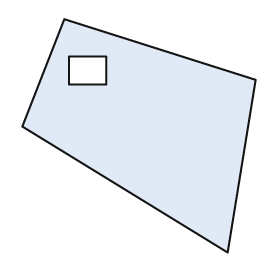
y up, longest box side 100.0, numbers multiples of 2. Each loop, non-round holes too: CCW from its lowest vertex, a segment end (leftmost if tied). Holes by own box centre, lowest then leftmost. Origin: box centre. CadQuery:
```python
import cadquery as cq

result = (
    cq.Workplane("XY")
    .moveTo(38.0, -50.0)
    .lineTo(50.0, 24.0)
    .lineTo(-32.0, 50.0)
    .lineTo(-50.0, 4.0)
    .close()
    .moveTo(-30.0, 22.0)
    .lineTo(-14.0, 22.0)
    .lineTo(-14.0, 34.0)
    .lineTo(-30.0, 34.0)
    .close()
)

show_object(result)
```